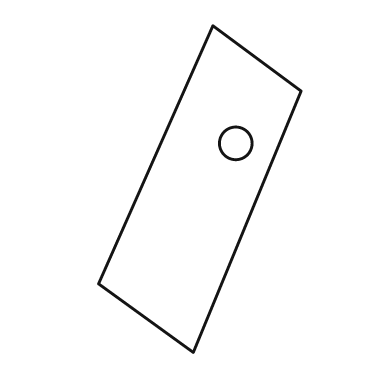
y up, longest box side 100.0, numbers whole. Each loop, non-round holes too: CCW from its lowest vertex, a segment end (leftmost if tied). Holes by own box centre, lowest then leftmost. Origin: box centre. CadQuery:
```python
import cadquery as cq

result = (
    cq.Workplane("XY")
    .moveTo(-2.0, -50.0)
    .lineTo(31.0, 30.0)
    .lineTo(4.0, 50.0)
    .lineTo(-31.0, -29.0)
    .close()
    .moveTo(11.0, 14.0)
    .circle(5.0)
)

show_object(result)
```